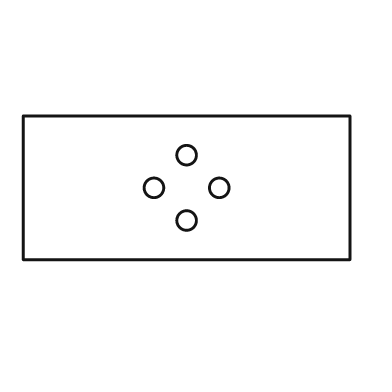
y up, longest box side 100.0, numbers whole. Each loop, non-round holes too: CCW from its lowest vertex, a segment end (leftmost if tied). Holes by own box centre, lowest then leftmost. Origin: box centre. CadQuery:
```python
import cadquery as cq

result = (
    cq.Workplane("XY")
    .moveTo(-50.0, -22.0)
    .lineTo(50.0, -22.0)
    .lineTo(50.0, 22.0)
    .lineTo(-50.0, 22.0)
    .close()
    .moveTo(0.0, -10.0)
    .circle(3.0)
    .moveTo(-10.0, 0.0)
    .circle(3.0)
    .moveTo(10.0, 0.0)
    .circle(3.0)
    .moveTo(0.0, 10.0)
    .circle(3.0)
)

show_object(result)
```